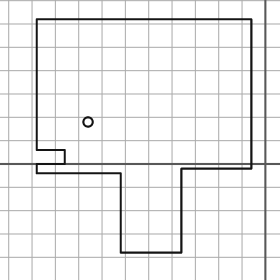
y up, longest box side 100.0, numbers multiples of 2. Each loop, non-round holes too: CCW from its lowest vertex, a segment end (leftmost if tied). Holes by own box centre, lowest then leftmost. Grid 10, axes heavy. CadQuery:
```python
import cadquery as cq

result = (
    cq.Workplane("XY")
    .moveTo(-62.0, -38.0)
    .lineTo(-36.0, -38.0)
    .lineTo(-36.0, -2.0)
    .lineTo(-6.0, -2.0)
    .lineTo(-6.0, 62.0)
    .lineTo(-98.0, 62.0)
    .lineTo(-98.0, 6.0)
    .lineTo(-86.0, 6.0)
    .lineTo(-86.0, 0.0)
    .lineTo(-98.0, 0.0)
    .lineTo(-98.0, -4.0)
    .lineTo(-62.0, -4.0)
    .close()
    .moveTo(-76.0, 18.0)
    .circle(2.0)
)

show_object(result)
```